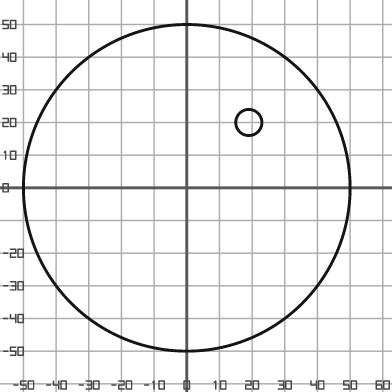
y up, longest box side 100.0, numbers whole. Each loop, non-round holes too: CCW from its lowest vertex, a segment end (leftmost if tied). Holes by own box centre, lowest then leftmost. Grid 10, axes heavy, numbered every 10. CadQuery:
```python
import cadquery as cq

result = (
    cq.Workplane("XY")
    .moveTo(0.0, 0.0)
    .circle(50.0)
    .moveTo(19.0, 20.0)
    .circle(4.0)
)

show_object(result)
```